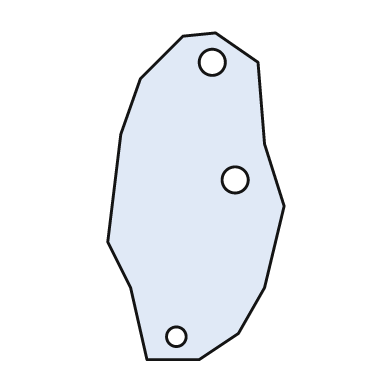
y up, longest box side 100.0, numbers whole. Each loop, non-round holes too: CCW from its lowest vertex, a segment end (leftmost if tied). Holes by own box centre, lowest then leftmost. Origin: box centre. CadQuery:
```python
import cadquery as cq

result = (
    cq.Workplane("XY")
    .moveTo(-15.0, -50.0)
    .lineTo(1.0, -50.0)
    .lineTo(13.0, -42.0)
    .lineTo(21.0, -28.0)
    .lineTo(27.0, -3.0)
    .lineTo(21.0, 16.0)
    .lineTo(19.0, 41.0)
    .lineTo(6.0, 50.0)
    .lineTo(-4.0, 49.0)
    .lineTo(-17.0, 36.0)
    .lineTo(-23.0, 19.0)
    .lineTo(-27.0, -14.0)
    .lineTo(-20.0, -28.0)
    .close()
    .moveTo(-6.0, -43.0)
    .circle(3.0)
    .moveTo(12.0, 5.0)
    .circle(4.0)
    .moveTo(5.0, 41.0)
    .circle(4.0)
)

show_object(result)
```